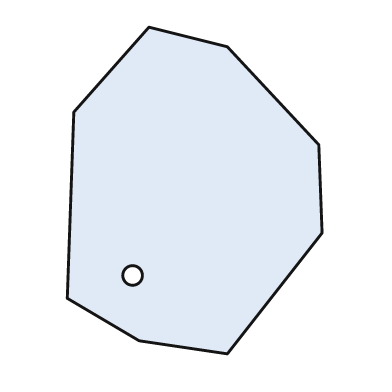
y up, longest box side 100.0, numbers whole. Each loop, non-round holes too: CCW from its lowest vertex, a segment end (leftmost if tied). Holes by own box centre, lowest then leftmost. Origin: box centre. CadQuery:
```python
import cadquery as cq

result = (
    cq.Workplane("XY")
    .moveTo(10.0, -50.0)
    .lineTo(39.0, -13.0)
    .lineTo(38.0, 14.0)
    .lineTo(10.0, 44.0)
    .lineTo(-14.0, 50.0)
    .lineTo(-37.0, 24.0)
    .lineTo(-39.0, -33.0)
    .lineTo(-17.0, -46.0)
    .close()
    .moveTo(-19.0, -26.0)
    .circle(3.0)
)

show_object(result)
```